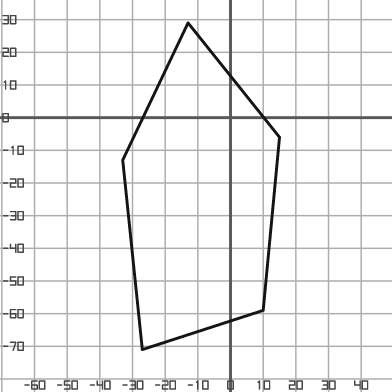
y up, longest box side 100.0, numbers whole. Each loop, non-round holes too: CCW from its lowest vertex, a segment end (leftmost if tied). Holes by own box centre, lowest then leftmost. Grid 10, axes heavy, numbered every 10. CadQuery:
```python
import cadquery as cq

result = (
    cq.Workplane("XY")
    .moveTo(-27.0, -71.0)
    .lineTo(10.0, -59.0)
    .lineTo(15.0, -6.0)
    .lineTo(-13.0, 29.0)
    .lineTo(-33.0, -13.0)
    .close()
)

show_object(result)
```